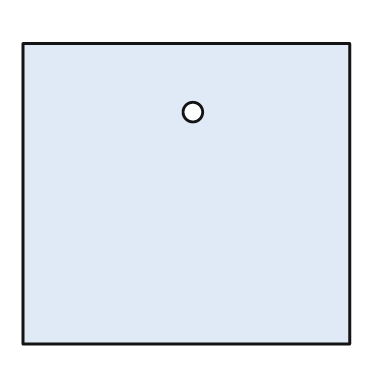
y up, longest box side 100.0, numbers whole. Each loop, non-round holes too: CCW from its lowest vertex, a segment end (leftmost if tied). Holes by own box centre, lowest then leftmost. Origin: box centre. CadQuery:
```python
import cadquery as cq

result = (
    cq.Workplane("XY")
    .moveTo(-50.0, -46.0)
    .lineTo(50.0, -46.0)
    .lineTo(50.0, 46.0)
    .lineTo(-50.0, 46.0)
    .close()
    .moveTo(2.0, 25.0)
    .circle(3.0)
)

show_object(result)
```